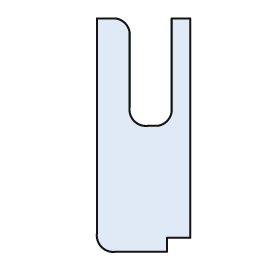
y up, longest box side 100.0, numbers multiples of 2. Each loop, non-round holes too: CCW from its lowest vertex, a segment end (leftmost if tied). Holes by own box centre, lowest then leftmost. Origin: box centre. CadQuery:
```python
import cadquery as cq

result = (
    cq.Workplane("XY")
    .moveTo(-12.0, -50.0)
    .lineTo(10.0, -50.0)
    .lineTo(10.0, -44.0)
    .lineTo(20.0, -44.0)
    .lineTo(20.0, 50.0)
    .lineTo(12.0, 50.0)
    .lineTo(12.0, 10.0)
    .threePointArc((10.0, 6.0), (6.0, 4.0))
    .lineTo(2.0, 4.0)
    .threePointArc((-4.0, 6.0), (-6.0, 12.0))
    .lineTo(-6.0, 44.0)
    .threePointArc((-8.0, 48.0), (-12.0, 50.0))
    .lineTo(-20.0, 50.0)
    .lineTo(-20.0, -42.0)
    .threePointArc((-18.0, -48.0), (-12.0, -50.0))
    .close()
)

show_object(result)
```